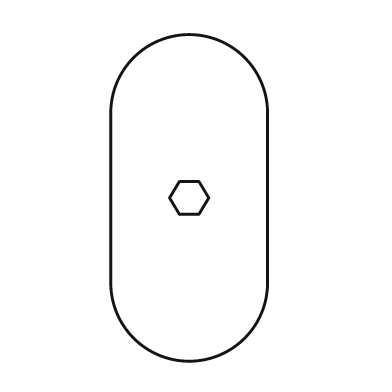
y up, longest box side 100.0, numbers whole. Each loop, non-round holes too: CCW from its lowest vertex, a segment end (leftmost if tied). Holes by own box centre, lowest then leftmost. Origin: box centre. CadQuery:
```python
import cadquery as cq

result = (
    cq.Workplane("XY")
    .moveTo(-24.0, -26.0)
    .threePointArc((0.0, -50.0), (24.0, -26.0))
    .lineTo(24.0, 26.0)
    .threePointArc((0.0, 50.0), (-24.0, 26.0))
    .close()
    .moveTo(-3.0, -5.0)
    .lineTo(3.0, -5.0)
    .lineTo(6.0, 0.0)
    .lineTo(3.0, 5.0)
    .lineTo(-3.0, 5.0)
    .lineTo(-6.0, 0.0)
    .close()
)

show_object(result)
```